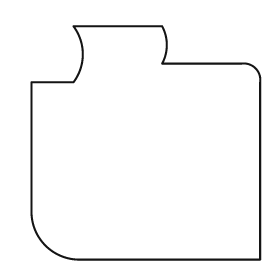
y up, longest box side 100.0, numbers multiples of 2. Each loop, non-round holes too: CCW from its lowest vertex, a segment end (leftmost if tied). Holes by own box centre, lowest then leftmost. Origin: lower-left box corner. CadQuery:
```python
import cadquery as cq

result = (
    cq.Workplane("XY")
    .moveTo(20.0, 0.0)
    .lineTo(98.0, 0.0)
    .lineTo(98.0, 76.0)
    .threePointArc((96.0, 82.0), (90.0, 84.0))
    .lineTo(56.0, 84.0)
    .threePointArc((58.0, 92.0), (56.0, 100.0))
    .lineTo(18.0, 100.0)
    .threePointArc((22.0, 88.0), (18.0, 76.0))
    .lineTo(0.0, 76.0)
    .lineTo(0.0, 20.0)
    .threePointArc((6.0, 6.0), (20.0, 0.0))
    .close()
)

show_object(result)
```